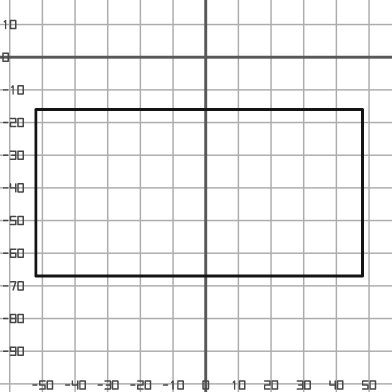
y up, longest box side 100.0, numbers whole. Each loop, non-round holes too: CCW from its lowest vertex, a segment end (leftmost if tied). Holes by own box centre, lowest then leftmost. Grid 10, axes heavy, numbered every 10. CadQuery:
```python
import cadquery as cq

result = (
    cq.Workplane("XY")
    .moveTo(-52.0, -67.0)
    .lineTo(48.0, -67.0)
    .lineTo(48.0, -16.0)
    .lineTo(-52.0, -16.0)
    .close()
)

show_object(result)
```